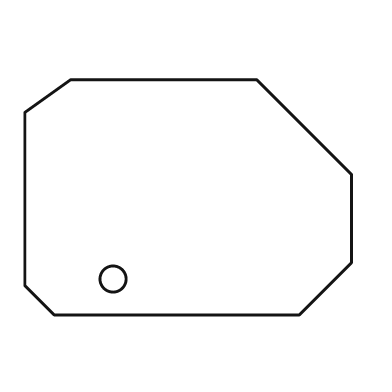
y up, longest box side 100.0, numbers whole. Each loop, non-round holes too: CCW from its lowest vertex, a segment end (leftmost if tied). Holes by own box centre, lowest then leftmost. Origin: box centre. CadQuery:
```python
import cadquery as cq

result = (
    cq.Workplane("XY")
    .moveTo(-41.0, -36.0)
    .lineTo(34.0, -36.0)
    .lineTo(50.0, -20.0)
    .lineTo(50.0, 7.0)
    .lineTo(21.0, 36.0)
    .lineTo(-36.0, 36.0)
    .lineTo(-50.0, 26.0)
    .lineTo(-50.0, -27.0)
    .close()
    .moveTo(-23.0, -25.0)
    .circle(4.0)
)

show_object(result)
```